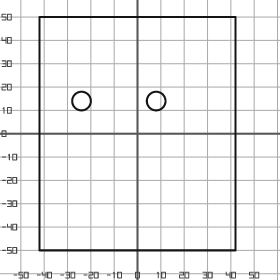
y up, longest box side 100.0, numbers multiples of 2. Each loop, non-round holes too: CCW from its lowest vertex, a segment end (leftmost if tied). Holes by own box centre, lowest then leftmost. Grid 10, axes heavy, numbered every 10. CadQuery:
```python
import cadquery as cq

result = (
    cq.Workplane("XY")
    .moveTo(-42.0, -50.0)
    .lineTo(42.0, -50.0)
    .lineTo(42.0, 50.0)
    .lineTo(-42.0, 50.0)
    .close()
    .moveTo(-24.0, 14.0)
    .circle(4.0)
    .moveTo(8.0, 14.0)
    .circle(4.0)
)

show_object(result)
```